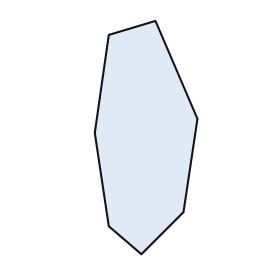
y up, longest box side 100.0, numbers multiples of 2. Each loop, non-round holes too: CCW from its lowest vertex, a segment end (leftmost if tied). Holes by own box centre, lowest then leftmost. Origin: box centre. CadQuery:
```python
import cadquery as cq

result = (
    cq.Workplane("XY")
    .moveTo(-2.0, -50.0)
    .lineTo(16.0, -32.0)
    .lineTo(22.0, 8.0)
    .lineTo(4.0, 50.0)
    .lineTo(-16.0, 44.0)
    .lineTo(-22.0, 2.0)
    .lineTo(-16.0, -38.0)
    .close()
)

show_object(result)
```